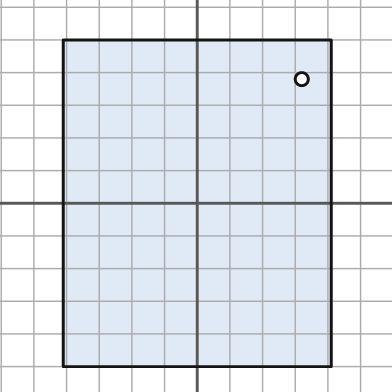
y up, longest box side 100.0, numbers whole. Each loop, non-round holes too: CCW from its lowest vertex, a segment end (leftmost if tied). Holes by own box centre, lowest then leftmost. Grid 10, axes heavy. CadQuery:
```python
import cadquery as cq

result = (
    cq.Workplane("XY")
    .moveTo(-41.0, -50.0)
    .lineTo(41.0, -50.0)
    .lineTo(41.0, 50.0)
    .lineTo(-41.0, 50.0)
    .close()
    .moveTo(32.0, 38.0)
    .circle(2.0)
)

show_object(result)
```